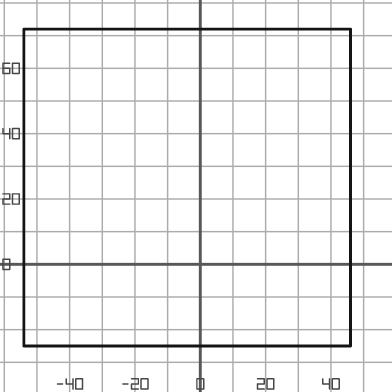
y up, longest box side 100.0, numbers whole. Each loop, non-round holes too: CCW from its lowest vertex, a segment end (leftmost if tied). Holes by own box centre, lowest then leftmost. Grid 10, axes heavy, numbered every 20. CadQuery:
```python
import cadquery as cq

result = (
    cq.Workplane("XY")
    .moveTo(-54.0, -25.0)
    .lineTo(46.0, -25.0)
    .lineTo(46.0, 72.0)
    .lineTo(-54.0, 72.0)
    .close()
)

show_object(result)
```